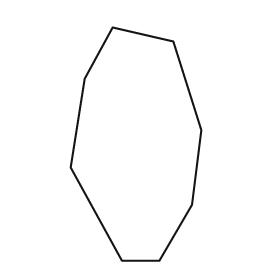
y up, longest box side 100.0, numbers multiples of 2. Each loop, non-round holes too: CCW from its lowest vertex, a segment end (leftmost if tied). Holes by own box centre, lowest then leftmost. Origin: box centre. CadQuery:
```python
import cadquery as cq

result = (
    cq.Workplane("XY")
    .moveTo(-6.0, -50.0)
    .lineTo(10.0, -50.0)
    .lineTo(24.0, -26.0)
    .lineTo(28.0, 6.0)
    .lineTo(16.0, 44.0)
    .lineTo(-10.0, 50.0)
    .lineTo(-22.0, 28.0)
    .lineTo(-28.0, -10.0)
    .close()
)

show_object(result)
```